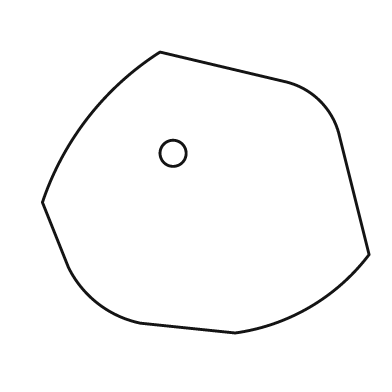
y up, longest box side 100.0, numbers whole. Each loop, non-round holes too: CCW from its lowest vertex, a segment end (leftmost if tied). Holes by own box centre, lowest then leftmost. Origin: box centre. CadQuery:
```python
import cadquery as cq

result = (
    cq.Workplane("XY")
    .moveTo(9.0, -43.0)
    .threePointArc((32.0, -35.0), (50.0, -19.0))
    .lineTo(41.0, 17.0)
    .threePointArc((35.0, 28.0), (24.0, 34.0))
    .lineTo(-14.0, 43.0)
    .threePointArc((-36.0, 23.0), (-50.0, -3.0))
    .lineTo(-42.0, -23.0)
    .threePointArc((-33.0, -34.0), (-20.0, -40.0))
    .close()
    .moveTo(-10.0, 12.0)
    .circle(4.0)
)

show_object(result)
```